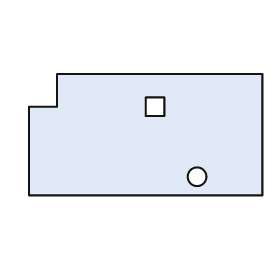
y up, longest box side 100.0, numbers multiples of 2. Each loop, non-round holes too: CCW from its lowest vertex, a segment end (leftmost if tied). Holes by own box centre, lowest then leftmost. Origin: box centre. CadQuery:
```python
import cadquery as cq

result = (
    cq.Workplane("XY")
    .moveTo(-50.0, -26.0)
    .lineTo(50.0, -26.0)
    .lineTo(50.0, 26.0)
    .lineTo(-38.0, 26.0)
    .lineTo(-38.0, 12.0)
    .lineTo(-50.0, 12.0)
    .close()
    .moveTo(22.0, -18.0)
    .circle(4.0)
    .moveTo(0.0, 8.0)
    .lineTo(8.0, 8.0)
    .lineTo(8.0, 16.0)
    .lineTo(0.0, 16.0)
    .close()
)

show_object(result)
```